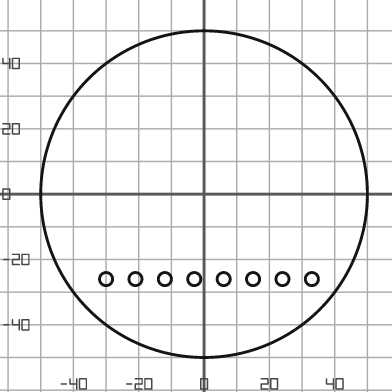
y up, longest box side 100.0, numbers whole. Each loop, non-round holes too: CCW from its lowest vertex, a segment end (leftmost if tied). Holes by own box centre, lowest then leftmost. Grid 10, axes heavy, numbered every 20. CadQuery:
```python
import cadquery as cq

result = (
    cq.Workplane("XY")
    .moveTo(0.0, 0.0)
    .circle(50.0)
    .moveTo(-30.0, -26.0)
    .circle(2.0)
    .moveTo(-21.0, -26.0)
    .circle(2.0)
    .moveTo(-12.0, -26.0)
    .circle(2.0)
    .moveTo(-3.0, -26.0)
    .circle(2.0)
    .moveTo(6.0, -26.0)
    .circle(2.0)
    .moveTo(15.0, -26.0)
    .circle(2.0)
    .moveTo(24.0, -26.0)
    .circle(2.0)
    .moveTo(33.0, -26.0)
    .circle(2.0)
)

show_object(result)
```